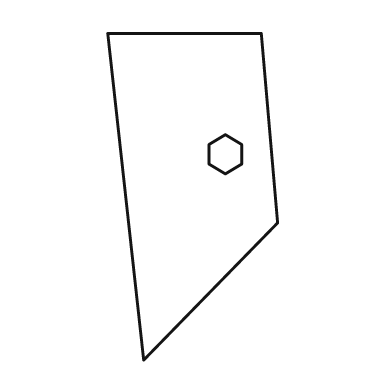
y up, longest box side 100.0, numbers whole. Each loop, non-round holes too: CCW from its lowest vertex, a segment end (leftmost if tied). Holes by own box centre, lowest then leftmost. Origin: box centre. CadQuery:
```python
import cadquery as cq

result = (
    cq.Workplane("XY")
    .moveTo(-15.0, -50.0)
    .lineTo(26.0, -8.0)
    .lineTo(21.0, 50.0)
    .lineTo(-26.0, 50.0)
    .close()
    .moveTo(10.0, 7.0)
    .lineTo(15.0, 10.0)
    .lineTo(15.0, 16.0)
    .lineTo(10.0, 19.0)
    .lineTo(5.0, 16.0)
    .lineTo(5.0, 10.0)
    .close()
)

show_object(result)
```